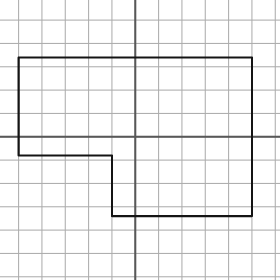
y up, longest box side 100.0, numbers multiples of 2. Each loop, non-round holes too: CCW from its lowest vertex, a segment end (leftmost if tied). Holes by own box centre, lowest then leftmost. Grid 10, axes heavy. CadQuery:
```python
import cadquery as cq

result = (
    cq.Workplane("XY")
    .moveTo(-10.0, -34.0)
    .lineTo(50.0, -34.0)
    .lineTo(50.0, 34.0)
    .lineTo(-50.0, 34.0)
    .lineTo(-50.0, -8.0)
    .lineTo(-10.0, -8.0)
    .close()
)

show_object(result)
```